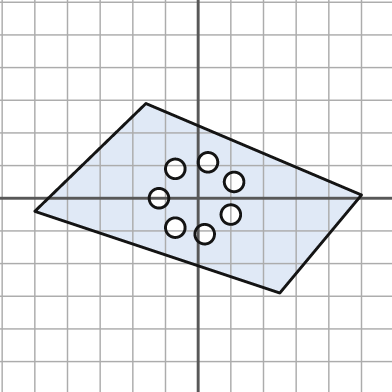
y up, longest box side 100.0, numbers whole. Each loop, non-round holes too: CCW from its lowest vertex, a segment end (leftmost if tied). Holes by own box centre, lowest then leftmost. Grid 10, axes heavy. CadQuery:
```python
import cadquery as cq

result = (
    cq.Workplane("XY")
    .moveTo(25.0, -29.0)
    .lineTo(50.0, 1.0)
    .lineTo(-16.0, 29.0)
    .lineTo(-50.0, -4.0)
    .close()
    .moveTo(2.0, -11.0)
    .circle(3.0)
    .moveTo(-7.0, -9.0)
    .circle(3.0)
    .moveTo(10.0, -5.0)
    .circle(3.0)
    .moveTo(-12.0, 0.0)
    .circle(3.0)
    .moveTo(11.0, 5.0)
    .circle(3.0)
    .moveTo(-7.0, 9.0)
    .circle(3.0)
    .moveTo(3.0, 11.0)
    .circle(3.0)
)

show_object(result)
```